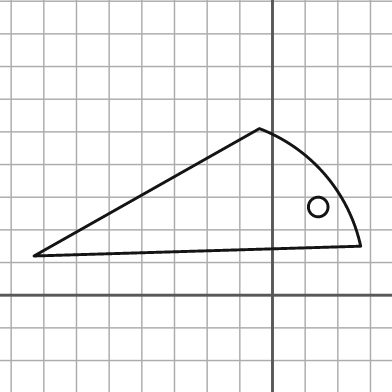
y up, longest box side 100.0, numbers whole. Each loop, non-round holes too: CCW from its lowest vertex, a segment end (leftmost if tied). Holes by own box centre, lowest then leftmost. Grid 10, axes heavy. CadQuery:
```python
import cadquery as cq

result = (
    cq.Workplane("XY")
    .moveTo(-73.0, 12.0)
    .lineTo(27.0, 15.0)
    .threePointArc((16.0, 37.0), (-4.0, 51.0))
    .close()
    .moveTo(14.0, 27.0)
    .circle(3.0)
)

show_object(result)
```